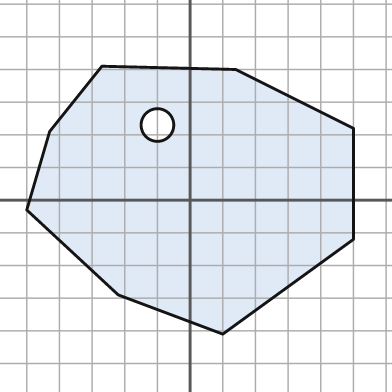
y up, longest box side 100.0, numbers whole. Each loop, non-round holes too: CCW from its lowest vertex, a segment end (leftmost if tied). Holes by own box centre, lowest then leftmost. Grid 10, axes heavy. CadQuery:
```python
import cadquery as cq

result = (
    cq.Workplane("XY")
    .moveTo(10.0, -41.0)
    .lineTo(50.0, -12.0)
    .lineTo(50.0, 22.0)
    .lineTo(14.0, 40.0)
    .lineTo(-27.0, 41.0)
    .lineTo(-43.0, 21.0)
    .lineTo(-50.0, -3.0)
    .lineTo(-22.0, -29.0)
    .close()
    .moveTo(-10.0, 23.0)
    .circle(5.0)
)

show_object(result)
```